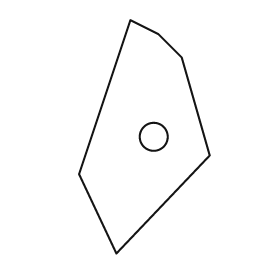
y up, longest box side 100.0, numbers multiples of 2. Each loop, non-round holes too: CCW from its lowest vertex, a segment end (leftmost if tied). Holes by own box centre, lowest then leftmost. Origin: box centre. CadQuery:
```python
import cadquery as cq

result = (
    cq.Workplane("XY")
    .moveTo(-12.0, -50.0)
    .lineTo(28.0, -8.0)
    .lineTo(16.0, 34.0)
    .lineTo(6.0, 44.0)
    .lineTo(-6.0, 50.0)
    .lineTo(-28.0, -16.0)
    .close()
    .moveTo(4.0, 0.0)
    .circle(6.0)
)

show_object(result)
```